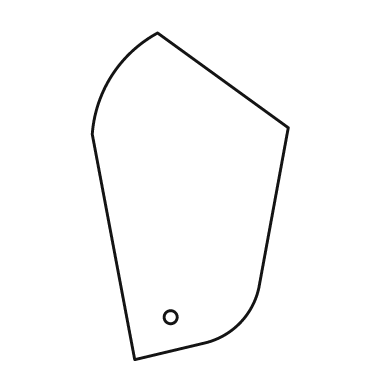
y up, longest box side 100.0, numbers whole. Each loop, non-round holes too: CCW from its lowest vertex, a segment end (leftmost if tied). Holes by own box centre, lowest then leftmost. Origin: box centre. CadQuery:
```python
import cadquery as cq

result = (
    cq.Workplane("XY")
    .moveTo(-17.0, -50.0)
    .lineTo(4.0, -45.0)
    .threePointArc((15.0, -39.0), (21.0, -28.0))
    .lineTo(30.0, 21.0)
    .lineTo(-10.0, 50.0)
    .threePointArc((-24.0, 37.0), (-30.0, 19.0))
    .close()
    .moveTo(-6.0, -37.0)
    .circle(2.0)
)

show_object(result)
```